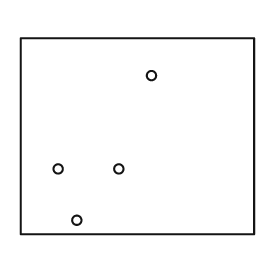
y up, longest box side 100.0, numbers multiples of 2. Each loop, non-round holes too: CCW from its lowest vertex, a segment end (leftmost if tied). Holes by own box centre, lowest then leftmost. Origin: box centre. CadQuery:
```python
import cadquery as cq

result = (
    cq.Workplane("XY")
    .moveTo(-50.0, -42.0)
    .lineTo(50.0, -42.0)
    .lineTo(50.0, 42.0)
    .lineTo(-50.0, 42.0)
    .close()
    .moveTo(-26.0, -36.0)
    .circle(2.0)
    .moveTo(-34.0, -14.0)
    .circle(2.0)
    .moveTo(-8.0, -14.0)
    .circle(2.0)
    .moveTo(6.0, 26.0)
    .circle(2.0)
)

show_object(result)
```